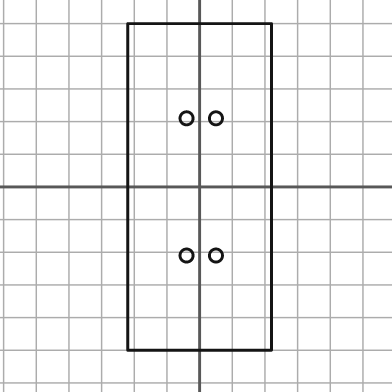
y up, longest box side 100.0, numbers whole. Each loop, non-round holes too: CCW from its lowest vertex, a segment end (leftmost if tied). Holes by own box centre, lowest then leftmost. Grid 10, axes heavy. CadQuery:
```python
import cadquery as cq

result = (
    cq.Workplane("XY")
    .moveTo(-22.0, -50.0)
    .lineTo(22.0, -50.0)
    .lineTo(22.0, 50.0)
    .lineTo(-22.0, 50.0)
    .close()
    .moveTo(-4.0, -21.0)
    .circle(2.0)
    .moveTo(5.0, -21.0)
    .circle(2.0)
    .moveTo(-4.0, 21.0)
    .circle(2.0)
    .moveTo(5.0, 21.0)
    .circle(2.0)
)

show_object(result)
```